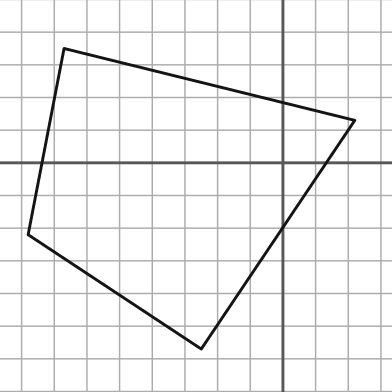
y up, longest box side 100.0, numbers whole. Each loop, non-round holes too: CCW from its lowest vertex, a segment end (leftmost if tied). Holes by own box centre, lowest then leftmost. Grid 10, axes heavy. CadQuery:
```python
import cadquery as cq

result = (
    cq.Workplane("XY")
    .moveTo(-25.0, -57.0)
    .lineTo(22.0, 13.0)
    .lineTo(-67.0, 35.0)
    .lineTo(-78.0, -22.0)
    .close()
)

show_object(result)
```